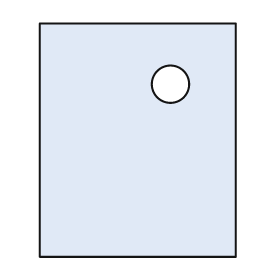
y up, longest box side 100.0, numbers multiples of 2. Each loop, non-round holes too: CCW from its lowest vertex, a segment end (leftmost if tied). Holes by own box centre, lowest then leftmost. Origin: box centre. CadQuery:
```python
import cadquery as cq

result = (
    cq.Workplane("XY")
    .moveTo(-42.0, -50.0)
    .lineTo(42.0, -50.0)
    .lineTo(42.0, 50.0)
    .lineTo(-42.0, 50.0)
    .close()
    .moveTo(14.0, 24.0)
    .circle(8.0)
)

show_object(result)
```